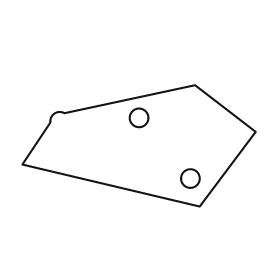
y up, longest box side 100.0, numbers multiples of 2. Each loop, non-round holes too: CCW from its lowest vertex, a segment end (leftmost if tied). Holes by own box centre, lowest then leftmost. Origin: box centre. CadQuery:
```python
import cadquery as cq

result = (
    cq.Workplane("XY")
    .moveTo(26.0, -26.0)
    .lineTo(50.0, 6.0)
    .lineTo(24.0, 26.0)
    .lineTo(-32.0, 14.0)
    .threePointArc((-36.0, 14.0), (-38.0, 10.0))
    .lineTo(-50.0, -8.0)
    .close()
    .moveTo(22.0, -14.0)
    .circle(4.0)
    .moveTo(0.0, 12.0)
    .circle(4.0)
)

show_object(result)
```